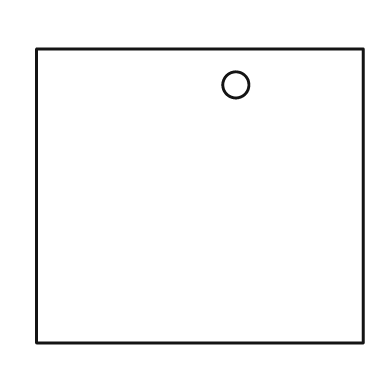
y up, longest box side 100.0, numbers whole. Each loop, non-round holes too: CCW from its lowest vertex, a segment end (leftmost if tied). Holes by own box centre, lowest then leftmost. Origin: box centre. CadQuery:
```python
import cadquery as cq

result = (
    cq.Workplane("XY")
    .moveTo(-50.0, -45.0)
    .lineTo(50.0, -45.0)
    .lineTo(50.0, 45.0)
    .lineTo(-50.0, 45.0)
    .close()
    .moveTo(11.0, 34.0)
    .circle(4.0)
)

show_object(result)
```